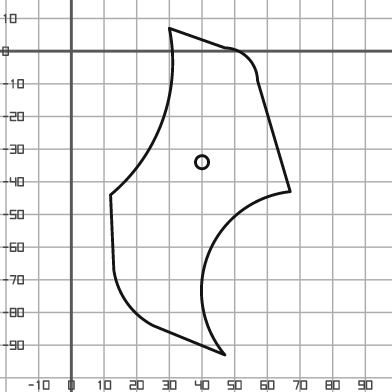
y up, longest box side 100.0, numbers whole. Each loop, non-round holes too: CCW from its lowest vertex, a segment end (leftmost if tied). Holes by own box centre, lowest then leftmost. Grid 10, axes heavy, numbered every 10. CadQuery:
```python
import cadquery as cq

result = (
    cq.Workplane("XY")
    .moveTo(47.0, -93.0)
    .threePointArc((42.0, -62.0), (67.0, -43.0))
    .lineTo(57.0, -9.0)
    .threePointArc((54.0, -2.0), (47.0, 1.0))
    .lineTo(30.0, 7.0)
    .threePointArc((28.0, -21.0), (12.0, -44.0))
    .lineTo(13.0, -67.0)
    .threePointArc((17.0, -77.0), (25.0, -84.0))
    .close()
    .moveTo(40.0, -34.0)
    .circle(2.0)
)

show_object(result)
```